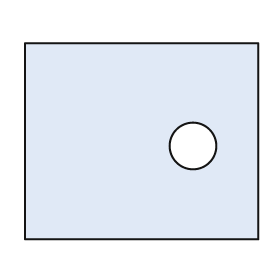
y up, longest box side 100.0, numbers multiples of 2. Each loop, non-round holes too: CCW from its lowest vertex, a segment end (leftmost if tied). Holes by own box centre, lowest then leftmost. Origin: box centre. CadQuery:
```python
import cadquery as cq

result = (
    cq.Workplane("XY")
    .moveTo(-50.0, -42.0)
    .lineTo(50.0, -42.0)
    .lineTo(50.0, 42.0)
    .lineTo(-50.0, 42.0)
    .close()
    .moveTo(22.0, -2.0)
    .circle(10.0)
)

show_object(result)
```